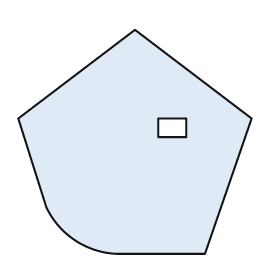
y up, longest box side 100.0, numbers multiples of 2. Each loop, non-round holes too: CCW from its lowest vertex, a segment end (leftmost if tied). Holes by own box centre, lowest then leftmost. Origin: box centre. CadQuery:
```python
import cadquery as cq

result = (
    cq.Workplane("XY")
    .moveTo(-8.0, -48.0)
    .lineTo(30.0, -48.0)
    .lineTo(50.0, 10.0)
    .lineTo(0.0, 48.0)
    .lineTo(-50.0, 10.0)
    .lineTo(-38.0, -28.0)
    .threePointArc((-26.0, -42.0), (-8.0, -48.0))
    .close()
    .moveTo(10.0, 2.0)
    .lineTo(22.0, 2.0)
    .lineTo(22.0, 10.0)
    .lineTo(10.0, 10.0)
    .close()
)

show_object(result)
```